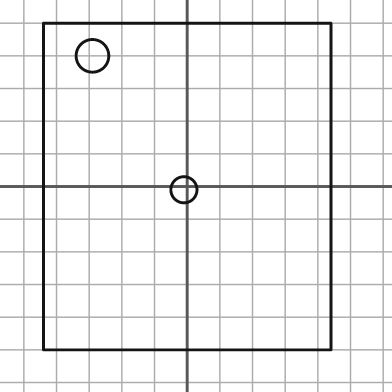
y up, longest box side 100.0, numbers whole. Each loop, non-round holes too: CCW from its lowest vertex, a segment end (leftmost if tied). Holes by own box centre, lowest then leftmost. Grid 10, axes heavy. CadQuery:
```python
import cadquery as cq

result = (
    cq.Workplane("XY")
    .moveTo(-44.0, -50.0)
    .lineTo(44.0, -50.0)
    .lineTo(44.0, 50.0)
    .lineTo(-44.0, 50.0)
    .close()
    .moveTo(-1.0, -1.0)
    .circle(4.0)
    .moveTo(-29.0, 40.0)
    .circle(5.0)
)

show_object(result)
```